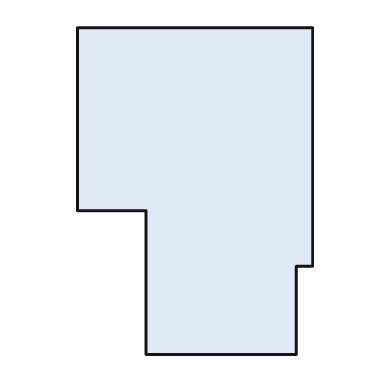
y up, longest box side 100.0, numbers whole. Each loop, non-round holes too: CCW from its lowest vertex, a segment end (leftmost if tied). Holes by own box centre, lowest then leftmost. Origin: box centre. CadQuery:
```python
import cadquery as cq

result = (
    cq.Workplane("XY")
    .moveTo(-15.0, -50.0)
    .lineTo(31.0, -50.0)
    .lineTo(31.0, -23.0)
    .lineTo(36.0, -23.0)
    .lineTo(36.0, 50.0)
    .lineTo(-36.0, 50.0)
    .lineTo(-36.0, -6.0)
    .lineTo(-15.0, -6.0)
    .close()
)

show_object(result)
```